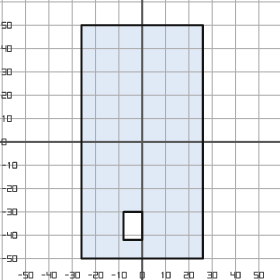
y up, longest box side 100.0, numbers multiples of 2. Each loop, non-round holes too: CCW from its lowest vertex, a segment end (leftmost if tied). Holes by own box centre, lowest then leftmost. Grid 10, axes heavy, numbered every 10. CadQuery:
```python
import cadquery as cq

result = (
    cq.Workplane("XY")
    .moveTo(-26.0, -50.0)
    .lineTo(26.0, -50.0)
    .lineTo(26.0, 50.0)
    .lineTo(-26.0, 50.0)
    .close()
    .moveTo(-8.0, -42.0)
    .lineTo(0.0, -42.0)
    .lineTo(0.0, -30.0)
    .lineTo(-8.0, -30.0)
    .close()
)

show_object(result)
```